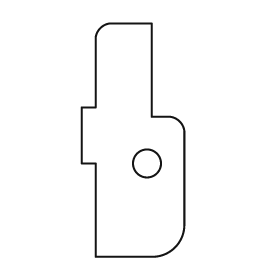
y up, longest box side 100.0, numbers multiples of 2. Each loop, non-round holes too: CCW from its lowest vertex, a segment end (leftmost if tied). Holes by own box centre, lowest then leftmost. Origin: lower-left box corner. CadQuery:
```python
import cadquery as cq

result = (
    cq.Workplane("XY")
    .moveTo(6.0, 0.0)
    .lineTo(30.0, 0.0)
    .threePointArc((40.0, 4.0), (44.0, 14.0))
    .lineTo(44.0, 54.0)
    .threePointArc((42.0, 58.0), (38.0, 60.0))
    .lineTo(30.0, 60.0)
    .lineTo(30.0, 100.0)
    .lineTo(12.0, 100.0)
    .threePointArc((8.0, 98.0), (6.0, 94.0))
    .lineTo(6.0, 64.0)
    .lineTo(0.0, 64.0)
    .lineTo(0.0, 40.0)
    .lineTo(6.0, 40.0)
    .close()
    .moveTo(28.0, 40.0)
    .circle(6.0)
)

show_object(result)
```